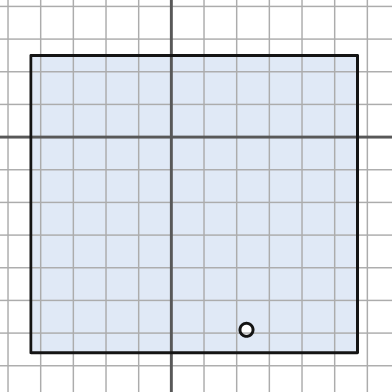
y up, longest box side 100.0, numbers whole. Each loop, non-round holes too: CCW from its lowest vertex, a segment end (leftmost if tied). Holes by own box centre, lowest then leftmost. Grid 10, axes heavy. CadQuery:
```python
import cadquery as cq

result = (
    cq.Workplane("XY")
    .moveTo(-43.0, -66.0)
    .lineTo(57.0, -66.0)
    .lineTo(57.0, 25.0)
    .lineTo(-43.0, 25.0)
    .close()
    .moveTo(23.0, -59.0)
    .circle(2.0)
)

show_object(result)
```